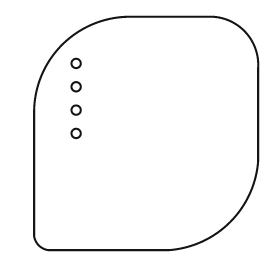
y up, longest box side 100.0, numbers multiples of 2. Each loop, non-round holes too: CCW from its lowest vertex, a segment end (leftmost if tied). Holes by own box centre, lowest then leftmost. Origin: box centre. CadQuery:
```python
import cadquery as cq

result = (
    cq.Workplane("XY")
    .moveTo(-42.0, -50.0)
    .lineTo(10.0, -50.0)
    .threePointArc((36.0, -38.0), (48.0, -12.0))
    .lineTo(48.0, 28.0)
    .threePointArc((42.0, 44.0), (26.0, 50.0))
    .lineTo(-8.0, 50.0)
    .threePointArc((-36.0, 38.0), (-48.0, 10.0))
    .lineTo(-48.0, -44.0)
    .threePointArc((-46.0, -48.0), (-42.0, -50.0))
    .close()
    .moveTo(-30.0, 0.0)
    .circle(2.0)
    .moveTo(-30.0, 10.0)
    .circle(2.0)
    .moveTo(-30.0, 20.0)
    .circle(2.0)
    .moveTo(-30.0, 30.0)
    .circle(2.0)
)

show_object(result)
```